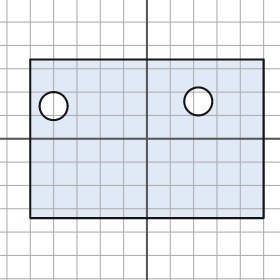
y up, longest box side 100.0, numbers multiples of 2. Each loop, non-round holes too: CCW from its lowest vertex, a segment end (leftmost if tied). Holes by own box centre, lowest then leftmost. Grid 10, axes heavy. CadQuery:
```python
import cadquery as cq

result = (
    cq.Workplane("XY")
    .moveTo(-50.0, -34.0)
    .lineTo(50.0, -34.0)
    .lineTo(50.0, 34.0)
    .lineTo(-50.0, 34.0)
    .close()
    .moveTo(-40.0, 14.0)
    .circle(6.0)
    .moveTo(22.0, 16.0)
    .circle(6.0)
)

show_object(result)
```